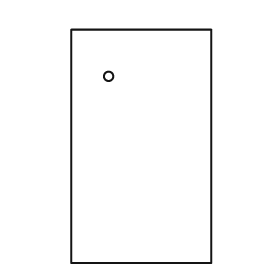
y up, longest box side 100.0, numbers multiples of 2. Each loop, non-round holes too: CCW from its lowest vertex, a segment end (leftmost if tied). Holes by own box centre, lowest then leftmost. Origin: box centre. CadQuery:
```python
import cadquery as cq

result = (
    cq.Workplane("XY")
    .moveTo(-30.0, -50.0)
    .lineTo(30.0, -50.0)
    .lineTo(30.0, 50.0)
    .lineTo(-30.0, 50.0)
    .close()
    .moveTo(-14.0, 30.0)
    .circle(2.0)
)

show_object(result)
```